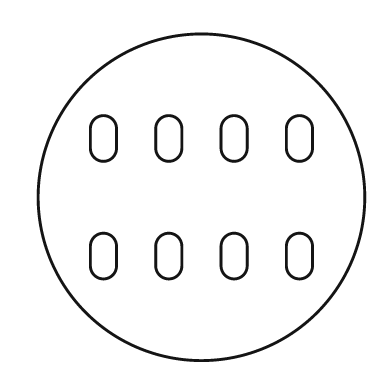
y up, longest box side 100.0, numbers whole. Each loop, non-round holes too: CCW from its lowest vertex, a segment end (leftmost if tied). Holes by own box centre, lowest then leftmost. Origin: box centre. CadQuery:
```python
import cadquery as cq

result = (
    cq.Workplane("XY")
    .moveTo(0.0, 0.0)
    .circle(50.0)
    .moveTo(-34.0, -21.0)
    .threePointArc((-30.0, -25.0), (-26.0, -21.0))
    .lineTo(-26.0, -15.0)
    .threePointArc((-30.0, -11.0), (-34.0, -15.0))
    .close()
    .moveTo(-14.0, -21.0)
    .threePointArc((-10.0, -25.0), (-6.0, -21.0))
    .lineTo(-6.0, -15.0)
    .threePointArc((-10.0, -11.0), (-14.0, -15.0))
    .close()
    .moveTo(6.0, -21.0)
    .threePointArc((10.0, -25.0), (14.0, -21.0))
    .lineTo(14.0, -15.0)
    .threePointArc((10.0, -11.0), (6.0, -15.0))
    .close()
    .moveTo(26.0, -21.0)
    .threePointArc((30.0, -25.0), (34.0, -21.0))
    .lineTo(34.0, -15.0)
    .threePointArc((30.0, -11.0), (26.0, -15.0))
    .close()
    .moveTo(-34.0, 15.0)
    .threePointArc((-30.0, 11.0), (-26.0, 15.0))
    .lineTo(-26.0, 21.0)
    .threePointArc((-30.0, 25.0), (-34.0, 21.0))
    .close()
    .moveTo(-14.0, 15.0)
    .threePointArc((-10.0, 11.0), (-6.0, 15.0))
    .lineTo(-6.0, 21.0)
    .threePointArc((-10.0, 25.0), (-14.0, 21.0))
    .close()
    .moveTo(6.0, 15.0)
    .threePointArc((10.0, 11.0), (14.0, 15.0))
    .lineTo(14.0, 21.0)
    .threePointArc((10.0, 25.0), (6.0, 21.0))
    .close()
    .moveTo(26.0, 15.0)
    .threePointArc((30.0, 11.0), (34.0, 15.0))
    .lineTo(34.0, 21.0)
    .threePointArc((30.0, 25.0), (26.0, 21.0))
    .close()
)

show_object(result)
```